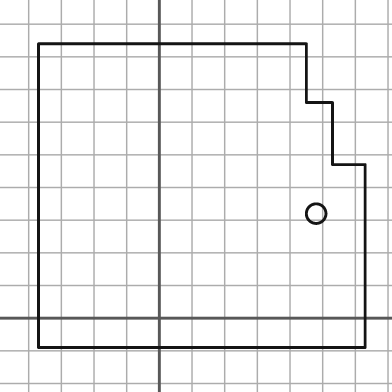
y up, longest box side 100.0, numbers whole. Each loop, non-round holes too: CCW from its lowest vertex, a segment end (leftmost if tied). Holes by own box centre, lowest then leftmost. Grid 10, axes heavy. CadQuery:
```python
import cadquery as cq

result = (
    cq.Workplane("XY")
    .moveTo(-37.0, -9.0)
    .lineTo(63.0, -9.0)
    .lineTo(63.0, 47.0)
    .lineTo(53.0, 47.0)
    .lineTo(53.0, 66.0)
    .lineTo(45.0, 66.0)
    .lineTo(45.0, 84.0)
    .lineTo(-37.0, 84.0)
    .close()
    .moveTo(48.0, 32.0)
    .circle(3.0)
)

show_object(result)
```